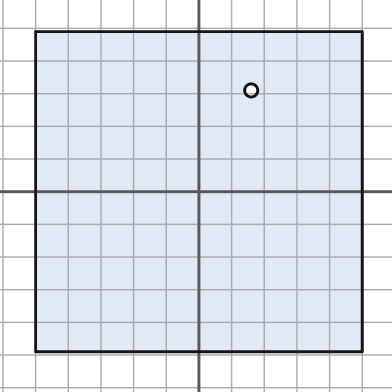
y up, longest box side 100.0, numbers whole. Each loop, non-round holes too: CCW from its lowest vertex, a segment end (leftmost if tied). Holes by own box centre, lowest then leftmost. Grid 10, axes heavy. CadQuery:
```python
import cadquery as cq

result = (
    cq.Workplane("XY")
    .moveTo(-50.0, -49.0)
    .lineTo(50.0, -49.0)
    .lineTo(50.0, 49.0)
    .lineTo(-50.0, 49.0)
    .close()
    .moveTo(16.0, 31.0)
    .circle(2.0)
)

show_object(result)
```